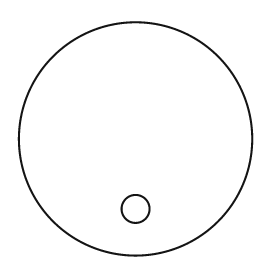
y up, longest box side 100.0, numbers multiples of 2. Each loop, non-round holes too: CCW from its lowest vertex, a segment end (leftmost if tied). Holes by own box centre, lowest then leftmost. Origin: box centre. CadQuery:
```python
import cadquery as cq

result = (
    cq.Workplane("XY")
    .moveTo(0.0, 0.0)
    .circle(50.0)
    .moveTo(0.0, -30.0)
    .circle(6.0)
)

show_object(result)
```